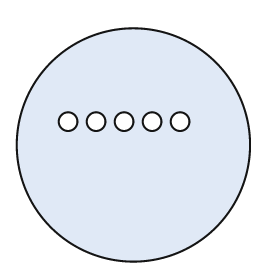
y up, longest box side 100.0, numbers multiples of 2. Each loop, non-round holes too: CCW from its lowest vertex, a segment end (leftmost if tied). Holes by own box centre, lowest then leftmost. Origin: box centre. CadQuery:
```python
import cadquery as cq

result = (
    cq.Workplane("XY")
    .moveTo(0.0, 0.0)
    .circle(50.0)
    .moveTo(-28.0, 10.0)
    .circle(4.0)
    .moveTo(-16.0, 10.0)
    .circle(4.0)
    .moveTo(-4.0, 10.0)
    .circle(4.0)
    .moveTo(8.0, 10.0)
    .circle(4.0)
    .moveTo(20.0, 10.0)
    .circle(4.0)
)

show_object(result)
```